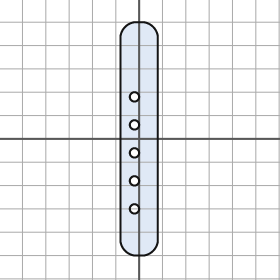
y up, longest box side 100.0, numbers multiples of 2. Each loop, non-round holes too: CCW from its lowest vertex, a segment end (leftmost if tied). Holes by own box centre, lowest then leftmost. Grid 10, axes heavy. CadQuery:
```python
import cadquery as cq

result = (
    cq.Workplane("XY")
    .moveTo(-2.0, -50.0)
    .lineTo(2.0, -50.0)
    .threePointArc((6.0, -48.0), (8.0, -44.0))
    .lineTo(8.0, 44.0)
    .threePointArc((6.0, 48.0), (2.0, 50.0))
    .lineTo(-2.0, 50.0)
    .threePointArc((-6.0, 48.0), (-8.0, 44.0))
    .lineTo(-8.0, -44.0)
    .threePointArc((-6.0, -48.0), (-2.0, -50.0))
    .close()
    .moveTo(-2.0, -30.0)
    .circle(2.0)
    .moveTo(-2.0, -18.0)
    .circle(2.0)
    .moveTo(-2.0, -6.0)
    .circle(2.0)
    .moveTo(-2.0, 6.0)
    .circle(2.0)
    .moveTo(-2.0, 18.0)
    .circle(2.0)
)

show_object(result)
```